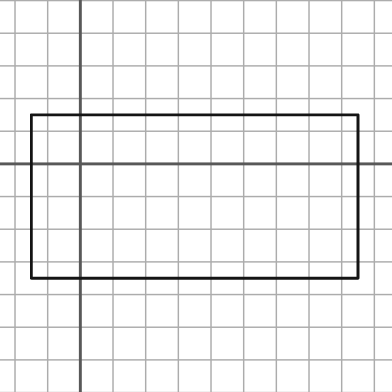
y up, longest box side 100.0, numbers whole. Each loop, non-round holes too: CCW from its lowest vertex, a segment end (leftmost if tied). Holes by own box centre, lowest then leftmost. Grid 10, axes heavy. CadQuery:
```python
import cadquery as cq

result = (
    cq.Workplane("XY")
    .moveTo(-15.0, -35.0)
    .lineTo(85.0, -35.0)
    .lineTo(85.0, 15.0)
    .lineTo(-15.0, 15.0)
    .close()
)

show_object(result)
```